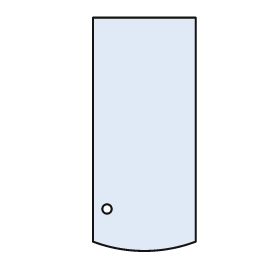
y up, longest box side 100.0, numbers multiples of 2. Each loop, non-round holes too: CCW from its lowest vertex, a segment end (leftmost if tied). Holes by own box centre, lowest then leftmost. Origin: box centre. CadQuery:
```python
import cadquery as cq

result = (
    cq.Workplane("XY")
    .moveTo(-22.0, -46.0)
    .threePointArc((0.0, -50.0), (22.0, -46.0))
    .lineTo(22.0, 50.0)
    .lineTo(-22.0, 50.0)
    .close()
    .moveTo(-16.0, -32.0)
    .circle(2.0)
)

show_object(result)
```